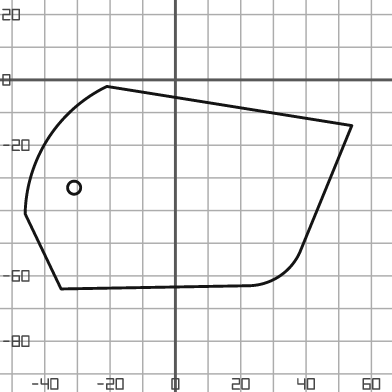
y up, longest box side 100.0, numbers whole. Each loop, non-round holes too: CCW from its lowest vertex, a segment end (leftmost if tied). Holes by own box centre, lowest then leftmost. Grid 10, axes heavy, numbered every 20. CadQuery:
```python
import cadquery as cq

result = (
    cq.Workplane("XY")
    .moveTo(-35.0, -64.0)
    .lineTo(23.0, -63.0)
    .threePointArc((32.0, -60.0), (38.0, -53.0))
    .lineTo(54.0, -14.0)
    .lineTo(-21.0, -2.0)
    .threePointArc((-39.0, -18.0), (-46.0, -41.0))
    .close()
    .moveTo(-31.0, -33.0)
    .circle(2.0)
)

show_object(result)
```